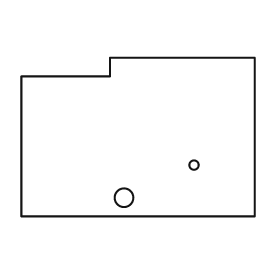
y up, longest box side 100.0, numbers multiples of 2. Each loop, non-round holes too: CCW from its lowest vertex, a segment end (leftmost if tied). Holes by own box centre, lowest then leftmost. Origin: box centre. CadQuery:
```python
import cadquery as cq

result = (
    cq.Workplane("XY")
    .moveTo(-50.0, -34.0)
    .lineTo(50.0, -34.0)
    .lineTo(50.0, 34.0)
    .lineTo(-12.0, 34.0)
    .lineTo(-12.0, 26.0)
    .lineTo(-50.0, 26.0)
    .close()
    .moveTo(-6.0, -26.0)
    .circle(4.0)
    .moveTo(24.0, -12.0)
    .circle(2.0)
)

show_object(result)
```